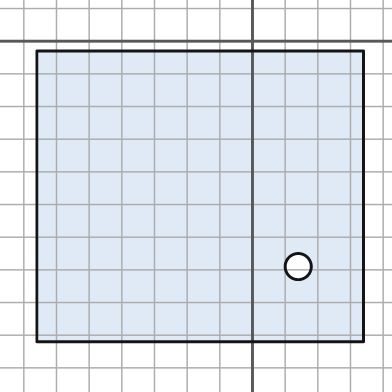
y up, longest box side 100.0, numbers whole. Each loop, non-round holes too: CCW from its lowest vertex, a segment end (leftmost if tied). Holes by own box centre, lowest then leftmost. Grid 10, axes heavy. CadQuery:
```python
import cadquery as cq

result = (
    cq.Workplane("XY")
    .moveTo(-66.0, -92.0)
    .lineTo(34.0, -92.0)
    .lineTo(34.0, -3.0)
    .lineTo(-66.0, -3.0)
    .close()
    .moveTo(14.0, -69.0)
    .circle(4.0)
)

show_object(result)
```